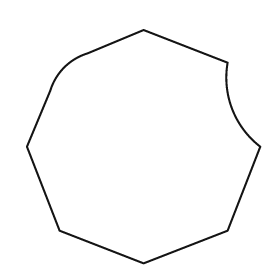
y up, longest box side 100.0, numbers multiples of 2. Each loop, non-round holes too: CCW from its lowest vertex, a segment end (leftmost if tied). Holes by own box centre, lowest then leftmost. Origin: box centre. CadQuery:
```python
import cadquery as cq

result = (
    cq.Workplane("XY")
    .moveTo(0.0, -50.0)
    .lineTo(36.0, -36.0)
    .lineTo(50.0, 0.0)
    .threePointArc((38.0, 16.0), (36.0, 36.0))
    .lineTo(0.0, 50.0)
    .lineTo(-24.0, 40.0)
    .threePointArc((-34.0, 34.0), (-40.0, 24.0))
    .lineTo(-50.0, 0.0)
    .lineTo(-36.0, -36.0)
    .close()
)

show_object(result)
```